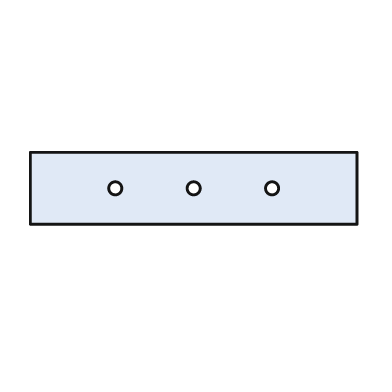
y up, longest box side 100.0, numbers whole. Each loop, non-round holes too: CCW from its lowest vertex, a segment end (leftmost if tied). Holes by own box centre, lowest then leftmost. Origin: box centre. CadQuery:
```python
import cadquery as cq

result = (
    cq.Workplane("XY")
    .moveTo(-50.0, -11.0)
    .lineTo(50.0, -11.0)
    .lineTo(50.0, 11.0)
    .lineTo(-50.0, 11.0)
    .close()
    .moveTo(-24.0, 0.0)
    .circle(2.0)
    .moveTo(0.0, 0.0)
    .circle(2.0)
    .moveTo(24.0, 0.0)
    .circle(2.0)
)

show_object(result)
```